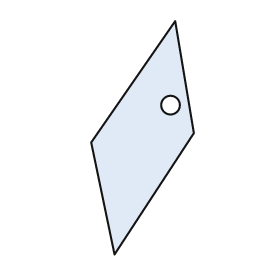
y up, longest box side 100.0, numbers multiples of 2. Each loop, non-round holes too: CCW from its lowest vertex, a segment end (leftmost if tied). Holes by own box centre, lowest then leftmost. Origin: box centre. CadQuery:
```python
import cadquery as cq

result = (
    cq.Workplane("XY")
    .moveTo(-12.0, -50.0)
    .lineTo(22.0, 2.0)
    .lineTo(14.0, 50.0)
    .lineTo(-22.0, -2.0)
    .close()
    .moveTo(12.0, 14.0)
    .circle(4.0)
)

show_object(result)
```